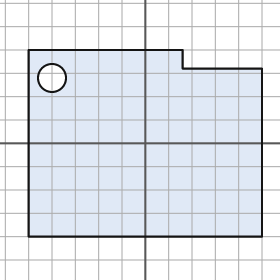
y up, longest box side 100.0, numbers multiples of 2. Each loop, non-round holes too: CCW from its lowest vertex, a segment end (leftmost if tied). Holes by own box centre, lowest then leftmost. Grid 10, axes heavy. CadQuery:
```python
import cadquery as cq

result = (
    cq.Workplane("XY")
    .moveTo(-50.0, -40.0)
    .lineTo(50.0, -40.0)
    .lineTo(50.0, 32.0)
    .lineTo(16.0, 32.0)
    .lineTo(16.0, 40.0)
    .lineTo(-50.0, 40.0)
    .close()
    .moveTo(-40.0, 28.0)
    .circle(6.0)
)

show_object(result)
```